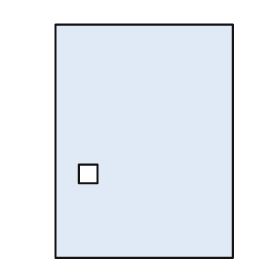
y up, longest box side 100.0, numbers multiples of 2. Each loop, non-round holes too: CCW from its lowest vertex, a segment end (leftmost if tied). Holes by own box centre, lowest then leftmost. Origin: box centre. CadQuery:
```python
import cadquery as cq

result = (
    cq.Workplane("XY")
    .moveTo(-38.0, -50.0)
    .lineTo(38.0, -50.0)
    .lineTo(38.0, 50.0)
    .lineTo(-38.0, 50.0)
    .close()
    .moveTo(-28.0, -18.0)
    .lineTo(-20.0, -18.0)
    .lineTo(-20.0, -10.0)
    .lineTo(-28.0, -10.0)
    .close()
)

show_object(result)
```